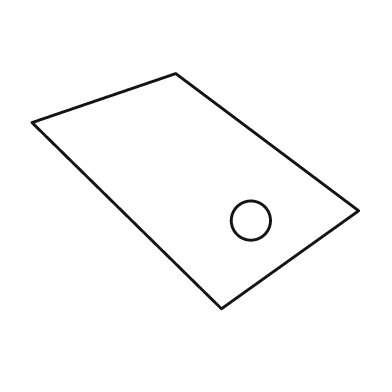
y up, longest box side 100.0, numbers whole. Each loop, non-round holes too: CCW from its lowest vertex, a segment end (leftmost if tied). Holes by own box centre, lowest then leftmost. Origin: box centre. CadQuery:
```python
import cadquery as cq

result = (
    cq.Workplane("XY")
    .moveTo(8.0, -36.0)
    .lineTo(50.0, -6.0)
    .lineTo(-6.0, 36.0)
    .lineTo(-50.0, 21.0)
    .close()
    .moveTo(17.0, -9.0)
    .circle(6.0)
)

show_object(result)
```